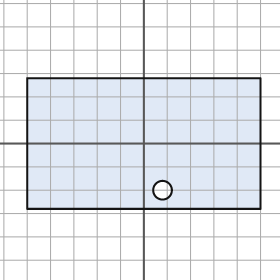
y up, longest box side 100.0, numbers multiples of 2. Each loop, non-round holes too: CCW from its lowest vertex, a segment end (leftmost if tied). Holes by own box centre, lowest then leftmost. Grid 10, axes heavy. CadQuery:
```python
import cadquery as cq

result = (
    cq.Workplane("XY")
    .moveTo(-50.0, -28.0)
    .lineTo(50.0, -28.0)
    .lineTo(50.0, 28.0)
    .lineTo(-50.0, 28.0)
    .close()
    .moveTo(8.0, -20.0)
    .circle(4.0)
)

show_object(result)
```